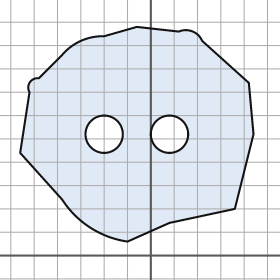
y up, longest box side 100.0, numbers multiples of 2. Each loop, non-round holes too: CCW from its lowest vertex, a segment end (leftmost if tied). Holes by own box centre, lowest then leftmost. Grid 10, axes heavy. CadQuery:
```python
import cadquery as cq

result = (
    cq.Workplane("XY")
    .moveTo(-10.0, 6.0)
    .lineTo(8.0, 14.0)
    .lineTo(36.0, 20.0)
    .lineTo(44.0, 52.0)
    .lineTo(42.0, 74.0)
    .lineTo(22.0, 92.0)
    .threePointArc((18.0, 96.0), (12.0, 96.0))
    .lineTo(-6.0, 98.0)
    .lineTo(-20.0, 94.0)
    .threePointArc((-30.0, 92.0), (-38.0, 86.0))
    .lineTo(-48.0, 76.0)
    .threePointArc((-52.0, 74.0), (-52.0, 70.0))
    .lineTo(-56.0, 44.0)
    .lineTo(-38.0, 24.0)
    .threePointArc((-26.0, 12.0), (-10.0, 6.0))
    .close()
    .moveTo(-20.0, 52.0)
    .circle(8.0)
    .moveTo(8.0, 52.0)
    .circle(8.0)
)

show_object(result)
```